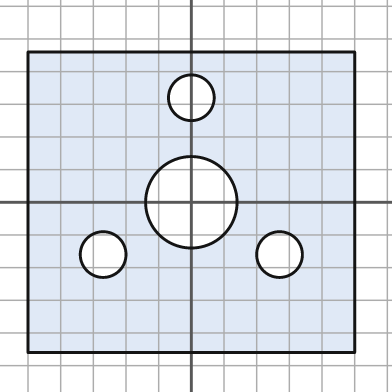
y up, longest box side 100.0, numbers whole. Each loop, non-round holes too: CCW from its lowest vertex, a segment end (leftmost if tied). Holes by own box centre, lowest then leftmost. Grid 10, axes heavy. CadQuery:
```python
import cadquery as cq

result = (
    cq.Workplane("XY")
    .moveTo(-50.0, -46.0)
    .lineTo(50.0, -46.0)
    .lineTo(50.0, 46.0)
    .lineTo(-50.0, 46.0)
    .close()
    .moveTo(-27.0, -16.0)
    .circle(7.0)
    .moveTo(27.0, -16.0)
    .circle(7.0)
    .moveTo(0.0, 0.0)
    .circle(14.0)
    .moveTo(0.0, 32.0)
    .circle(7.0)
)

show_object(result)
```